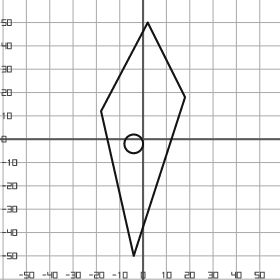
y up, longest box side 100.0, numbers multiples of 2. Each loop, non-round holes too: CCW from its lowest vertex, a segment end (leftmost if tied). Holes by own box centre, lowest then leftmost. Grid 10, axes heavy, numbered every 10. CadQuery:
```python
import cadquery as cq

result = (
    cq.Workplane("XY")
    .moveTo(-4.0, -50.0)
    .lineTo(18.0, 18.0)
    .lineTo(2.0, 50.0)
    .lineTo(-18.0, 12.0)
    .close()
    .moveTo(-4.0, -2.0)
    .circle(4.0)
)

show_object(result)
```